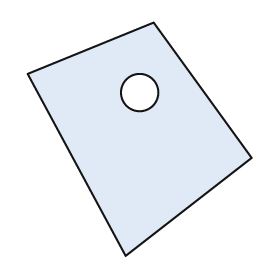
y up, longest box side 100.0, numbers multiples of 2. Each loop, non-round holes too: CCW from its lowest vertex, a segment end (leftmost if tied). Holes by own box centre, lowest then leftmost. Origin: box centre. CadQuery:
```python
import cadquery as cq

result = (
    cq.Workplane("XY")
    .moveTo(-6.0, -50.0)
    .lineTo(48.0, -8.0)
    .lineTo(6.0, 50.0)
    .lineTo(-48.0, 28.0)
    .close()
    .moveTo(0.0, 20.0)
    .circle(8.0)
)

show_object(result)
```